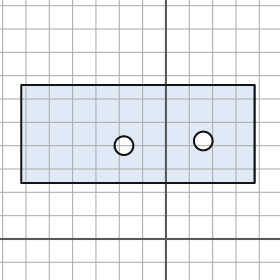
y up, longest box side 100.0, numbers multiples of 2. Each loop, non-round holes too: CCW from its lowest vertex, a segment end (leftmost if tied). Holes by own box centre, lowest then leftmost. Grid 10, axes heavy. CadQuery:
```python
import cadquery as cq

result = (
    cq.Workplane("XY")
    .moveTo(-62.0, 24.0)
    .lineTo(38.0, 24.0)
    .lineTo(38.0, 66.0)
    .lineTo(-62.0, 66.0)
    .close()
    .moveTo(-18.0, 40.0)
    .circle(4.0)
    .moveTo(16.0, 42.0)
    .circle(4.0)
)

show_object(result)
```